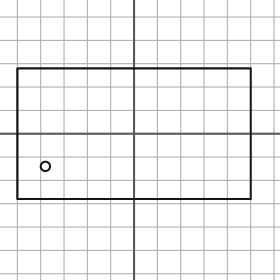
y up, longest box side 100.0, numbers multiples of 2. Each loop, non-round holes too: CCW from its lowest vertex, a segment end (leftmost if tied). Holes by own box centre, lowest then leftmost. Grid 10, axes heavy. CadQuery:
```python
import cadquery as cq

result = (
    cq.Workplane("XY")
    .moveTo(-50.0, -28.0)
    .lineTo(50.0, -28.0)
    .lineTo(50.0, 28.0)
    .lineTo(-50.0, 28.0)
    .close()
    .moveTo(-38.0, -14.0)
    .circle(2.0)
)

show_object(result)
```